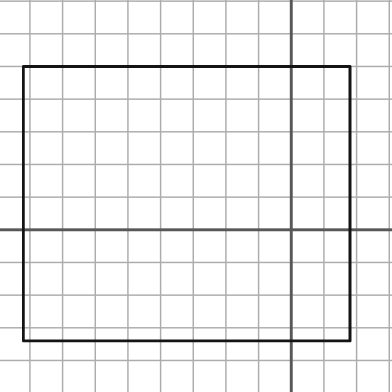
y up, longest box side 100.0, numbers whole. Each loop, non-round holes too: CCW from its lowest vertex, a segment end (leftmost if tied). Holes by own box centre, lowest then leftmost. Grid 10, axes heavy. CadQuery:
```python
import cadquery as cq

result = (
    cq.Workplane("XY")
    .moveTo(-82.0, -34.0)
    .lineTo(18.0, -34.0)
    .lineTo(18.0, 50.0)
    .lineTo(-82.0, 50.0)
    .close()
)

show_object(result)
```